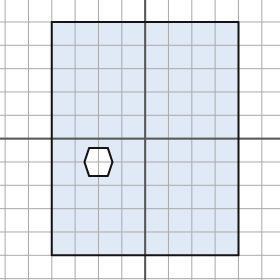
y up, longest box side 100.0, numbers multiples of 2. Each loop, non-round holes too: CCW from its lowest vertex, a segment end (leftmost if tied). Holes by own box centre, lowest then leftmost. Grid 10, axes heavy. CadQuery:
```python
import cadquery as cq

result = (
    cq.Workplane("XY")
    .moveTo(-40.0, -50.0)
    .lineTo(40.0, -50.0)
    .lineTo(40.0, 50.0)
    .lineTo(-40.0, 50.0)
    .close()
    .moveTo(-24.0, -16.0)
    .lineTo(-16.0, -16.0)
    .lineTo(-14.0, -10.0)
    .lineTo(-16.0, -4.0)
    .lineTo(-24.0, -4.0)
    .lineTo(-26.0, -10.0)
    .close()
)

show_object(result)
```